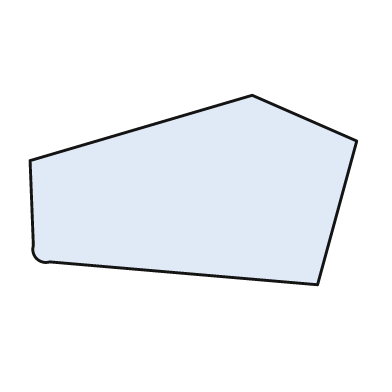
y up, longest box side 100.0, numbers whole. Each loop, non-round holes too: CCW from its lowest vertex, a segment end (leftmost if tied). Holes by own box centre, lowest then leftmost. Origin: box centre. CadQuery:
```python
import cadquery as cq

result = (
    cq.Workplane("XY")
    .moveTo(38.0, -29.0)
    .lineTo(50.0, 15.0)
    .lineTo(18.0, 29.0)
    .lineTo(-50.0, 9.0)
    .lineTo(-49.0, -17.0)
    .threePointArc((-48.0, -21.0), (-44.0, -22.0))
    .close()
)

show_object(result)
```